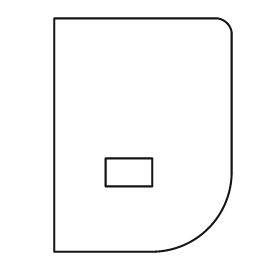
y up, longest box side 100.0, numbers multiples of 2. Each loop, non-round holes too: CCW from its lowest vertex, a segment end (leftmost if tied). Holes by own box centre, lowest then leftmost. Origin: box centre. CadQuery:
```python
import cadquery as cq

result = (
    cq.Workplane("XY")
    .moveTo(-38.0, -50.0)
    .lineTo(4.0, -50.0)
    .threePointArc((28.0, -40.0), (38.0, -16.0))
    .lineTo(38.0, 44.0)
    .threePointArc((36.0, 48.0), (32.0, 50.0))
    .lineTo(-38.0, 50.0)
    .close()
    .moveTo(-16.0, -22.0)
    .lineTo(4.0, -22.0)
    .lineTo(4.0, -10.0)
    .lineTo(-16.0, -10.0)
    .close()
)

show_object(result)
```